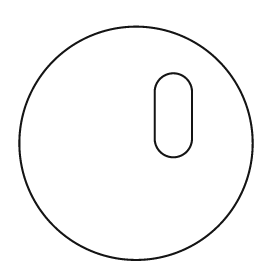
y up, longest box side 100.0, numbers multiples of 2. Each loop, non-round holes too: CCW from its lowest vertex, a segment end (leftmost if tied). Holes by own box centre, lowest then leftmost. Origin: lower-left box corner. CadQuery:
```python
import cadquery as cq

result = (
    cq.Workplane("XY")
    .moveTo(50.0, 50.0)
    .circle(50.0)
    .moveTo(58.0, 52.0)
    .threePointArc((66.0, 44.0), (74.0, 52.0))
    .lineTo(74.0, 72.0)
    .threePointArc((66.0, 80.0), (58.0, 72.0))
    .close()
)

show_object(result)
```